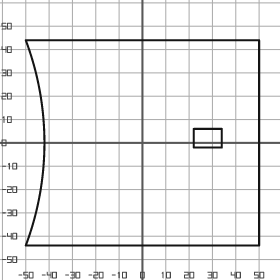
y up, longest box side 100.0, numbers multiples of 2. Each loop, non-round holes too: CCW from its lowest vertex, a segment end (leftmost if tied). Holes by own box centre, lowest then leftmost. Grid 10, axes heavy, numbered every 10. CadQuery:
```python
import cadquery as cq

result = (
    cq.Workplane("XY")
    .moveTo(-50.0, -44.0)
    .lineTo(50.0, -44.0)
    .lineTo(50.0, 44.0)
    .lineTo(-50.0, 44.0)
    .threePointArc((-42.0, 0.0), (-50.0, -44.0))
    .close()
    .moveTo(22.0, -2.0)
    .lineTo(34.0, -2.0)
    .lineTo(34.0, 6.0)
    .lineTo(22.0, 6.0)
    .close()
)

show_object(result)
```